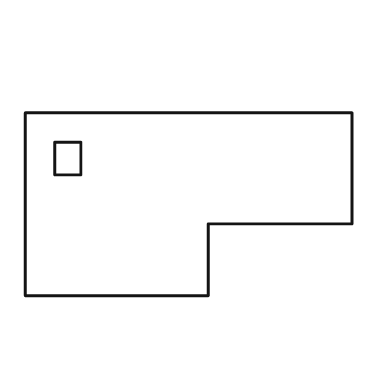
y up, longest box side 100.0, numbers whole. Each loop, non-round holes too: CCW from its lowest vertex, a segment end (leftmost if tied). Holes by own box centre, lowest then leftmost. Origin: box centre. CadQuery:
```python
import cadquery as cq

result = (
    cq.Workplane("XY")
    .moveTo(-50.0, -28.0)
    .lineTo(6.0, -28.0)
    .lineTo(6.0, -6.0)
    .lineTo(50.0, -6.0)
    .lineTo(50.0, 28.0)
    .lineTo(-50.0, 28.0)
    .close()
    .moveTo(-41.0, 9.0)
    .lineTo(-33.0, 9.0)
    .lineTo(-33.0, 19.0)
    .lineTo(-41.0, 19.0)
    .close()
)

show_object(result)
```